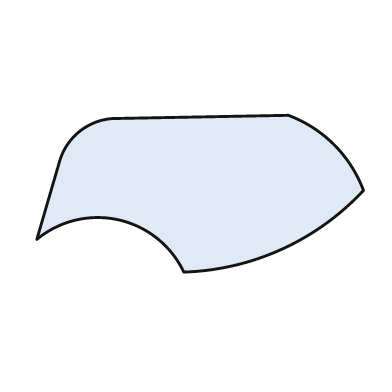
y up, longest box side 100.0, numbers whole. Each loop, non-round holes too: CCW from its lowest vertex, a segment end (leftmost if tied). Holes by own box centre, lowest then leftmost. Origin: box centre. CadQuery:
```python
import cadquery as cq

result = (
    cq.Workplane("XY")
    .moveTo(-5.0, -24.0)
    .threePointArc((25.0, -17.0), (50.0, 1.0))
    .threePointArc((41.0, 15.0), (27.0, 24.0))
    .lineTo(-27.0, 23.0)
    .threePointArc((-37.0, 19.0), (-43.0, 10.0))
    .lineTo(-50.0, -14.0)
    .threePointArc((-25.0, -8.0), (-5.0, -24.0))
    .close()
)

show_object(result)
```